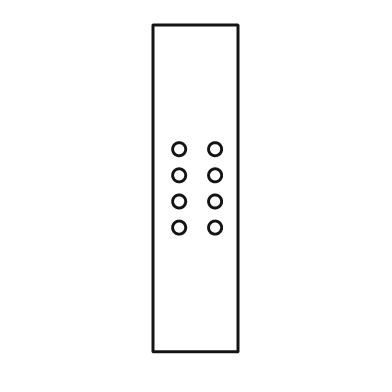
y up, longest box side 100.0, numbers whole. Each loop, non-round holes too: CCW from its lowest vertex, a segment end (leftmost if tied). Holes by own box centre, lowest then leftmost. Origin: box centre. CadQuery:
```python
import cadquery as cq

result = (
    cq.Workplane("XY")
    .moveTo(-13.0, -50.0)
    .lineTo(13.0, -50.0)
    .lineTo(13.0, 50.0)
    .lineTo(-13.0, 50.0)
    .close()
    .moveTo(-5.0, -12.0)
    .circle(2.0)
    .moveTo(6.0, -12.0)
    .circle(2.0)
    .moveTo(-5.0, -4.0)
    .circle(2.0)
    .moveTo(6.0, -4.0)
    .circle(2.0)
    .moveTo(-5.0, 4.0)
    .circle(2.0)
    .moveTo(6.0, 4.0)
    .circle(2.0)
    .moveTo(-5.0, 12.0)
    .circle(2.0)
    .moveTo(6.0, 12.0)
    .circle(2.0)
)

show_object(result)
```